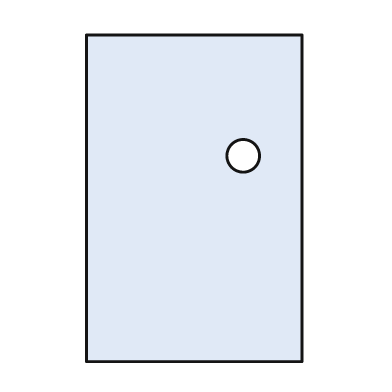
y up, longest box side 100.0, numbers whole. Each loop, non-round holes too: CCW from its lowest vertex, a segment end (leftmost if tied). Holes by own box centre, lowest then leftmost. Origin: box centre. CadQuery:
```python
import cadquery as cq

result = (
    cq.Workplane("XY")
    .moveTo(-33.0, -50.0)
    .lineTo(33.0, -50.0)
    .lineTo(33.0, 50.0)
    .lineTo(-33.0, 50.0)
    .close()
    .moveTo(15.0, 13.0)
    .circle(5.0)
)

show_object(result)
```